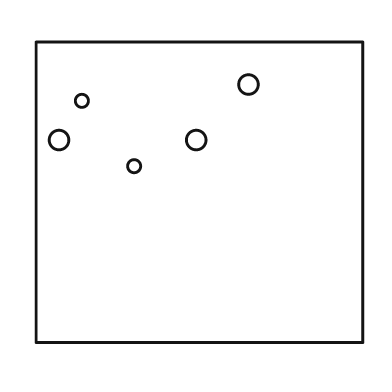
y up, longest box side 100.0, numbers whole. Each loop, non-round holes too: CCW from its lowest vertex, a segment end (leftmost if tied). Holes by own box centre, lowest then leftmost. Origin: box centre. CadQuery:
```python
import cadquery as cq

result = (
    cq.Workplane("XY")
    .moveTo(-50.0, -46.0)
    .lineTo(50.0, -46.0)
    .lineTo(50.0, 46.0)
    .lineTo(-50.0, 46.0)
    .close()
    .moveTo(-20.0, 8.0)
    .circle(2.0)
    .moveTo(-43.0, 16.0)
    .circle(3.0)
    .moveTo(-1.0, 16.0)
    .circle(3.0)
    .moveTo(-36.0, 28.0)
    .circle(2.0)
    .moveTo(15.0, 33.0)
    .circle(3.0)
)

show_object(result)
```